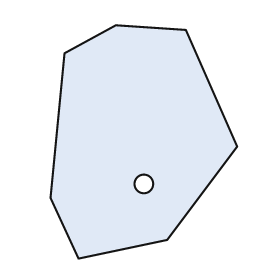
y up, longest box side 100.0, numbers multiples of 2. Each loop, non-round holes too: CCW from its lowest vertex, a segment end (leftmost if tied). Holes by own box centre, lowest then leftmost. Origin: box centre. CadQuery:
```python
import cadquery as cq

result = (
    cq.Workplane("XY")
    .moveTo(-28.0, -50.0)
    .lineTo(10.0, -42.0)
    .lineTo(40.0, -2.0)
    .lineTo(18.0, 48.0)
    .lineTo(-12.0, 50.0)
    .lineTo(-34.0, 38.0)
    .lineTo(-40.0, -24.0)
    .close()
    .moveTo(0.0, -18.0)
    .circle(4.0)
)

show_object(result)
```